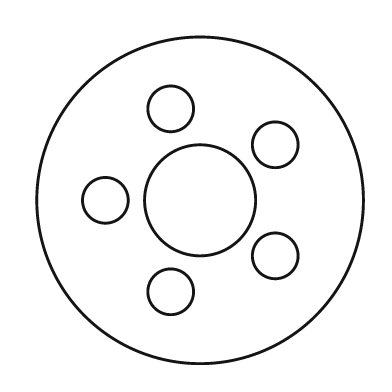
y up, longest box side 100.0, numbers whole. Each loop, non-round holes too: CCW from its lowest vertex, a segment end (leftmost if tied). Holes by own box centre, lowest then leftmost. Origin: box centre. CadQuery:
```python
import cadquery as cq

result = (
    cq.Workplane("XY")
    .moveTo(0.0, 0.0)
    .circle(50.0)
    .moveTo(-9.0, -28.0)
    .circle(7.0)
    .moveTo(23.0, -17.0)
    .circle(7.0)
    .moveTo(-29.0, 0.0)
    .circle(7.0)
    .moveTo(0.0, 0.0)
    .circle(17.0)
    .moveTo(23.0, 17.0)
    .circle(7.0)
    .moveTo(-9.0, 28.0)
    .circle(7.0)
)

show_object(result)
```